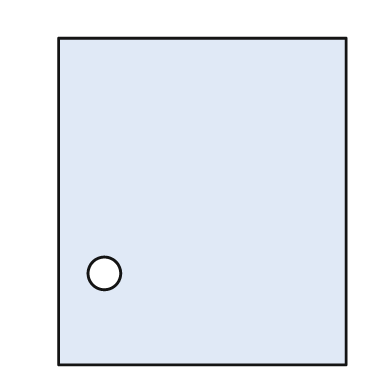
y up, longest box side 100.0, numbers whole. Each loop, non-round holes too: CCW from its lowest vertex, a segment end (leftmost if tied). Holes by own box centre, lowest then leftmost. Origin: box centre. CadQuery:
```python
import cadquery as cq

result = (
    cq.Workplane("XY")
    .moveTo(-44.0, -50.0)
    .lineTo(44.0, -50.0)
    .lineTo(44.0, 50.0)
    .lineTo(-44.0, 50.0)
    .close()
    .moveTo(-30.0, -22.0)
    .circle(5.0)
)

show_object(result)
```